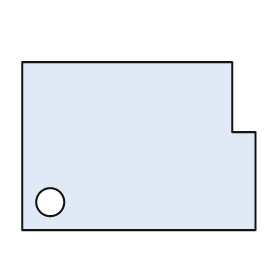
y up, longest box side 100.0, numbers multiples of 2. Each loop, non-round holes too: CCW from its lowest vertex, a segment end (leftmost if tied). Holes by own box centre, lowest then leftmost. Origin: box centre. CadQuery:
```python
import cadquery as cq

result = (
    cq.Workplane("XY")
    .moveTo(-50.0, -36.0)
    .lineTo(50.0, -36.0)
    .lineTo(50.0, 6.0)
    .lineTo(40.0, 6.0)
    .lineTo(40.0, 36.0)
    .lineTo(-50.0, 36.0)
    .close()
    .moveTo(-38.0, -24.0)
    .circle(6.0)
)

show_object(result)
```